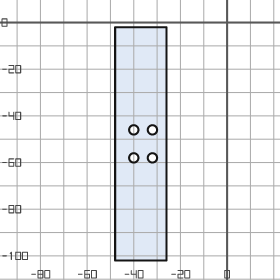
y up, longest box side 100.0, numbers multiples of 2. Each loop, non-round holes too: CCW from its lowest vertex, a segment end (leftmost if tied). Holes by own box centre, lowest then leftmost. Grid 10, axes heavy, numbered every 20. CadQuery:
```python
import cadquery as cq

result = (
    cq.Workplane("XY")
    .moveTo(-48.0, -102.0)
    .lineTo(-26.0, -102.0)
    .lineTo(-26.0, -2.0)
    .lineTo(-48.0, -2.0)
    .close()
    .moveTo(-40.0, -58.0)
    .circle(2.0)
    .moveTo(-32.0, -58.0)
    .circle(2.0)
    .moveTo(-40.0, -46.0)
    .circle(2.0)
    .moveTo(-32.0, -46.0)
    .circle(2.0)
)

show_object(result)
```